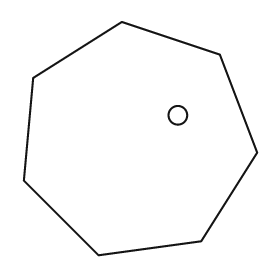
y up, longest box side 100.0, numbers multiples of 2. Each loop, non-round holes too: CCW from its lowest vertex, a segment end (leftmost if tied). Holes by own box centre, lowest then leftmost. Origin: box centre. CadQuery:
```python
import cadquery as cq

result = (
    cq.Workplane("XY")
    .moveTo(-18.0, -50.0)
    .lineTo(26.0, -44.0)
    .lineTo(50.0, -6.0)
    .lineTo(34.0, 36.0)
    .lineTo(-8.0, 50.0)
    .lineTo(-46.0, 26.0)
    .lineTo(-50.0, -18.0)
    .close()
    .moveTo(16.0, 10.0)
    .circle(4.0)
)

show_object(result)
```